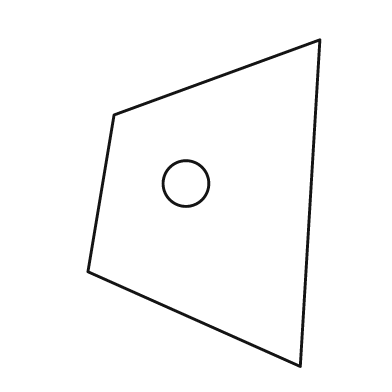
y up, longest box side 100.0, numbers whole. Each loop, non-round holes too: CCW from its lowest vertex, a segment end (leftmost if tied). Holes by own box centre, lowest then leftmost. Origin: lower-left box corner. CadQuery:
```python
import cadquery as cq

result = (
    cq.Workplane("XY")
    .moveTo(65.0, 0.0)
    .lineTo(71.0, 100.0)
    .lineTo(8.0, 77.0)
    .lineTo(0.0, 29.0)
    .close()
    .moveTo(30.0, 56.0)
    .circle(7.0)
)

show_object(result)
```